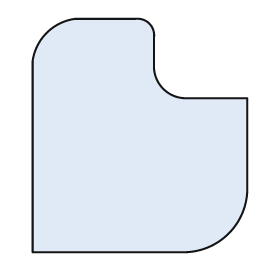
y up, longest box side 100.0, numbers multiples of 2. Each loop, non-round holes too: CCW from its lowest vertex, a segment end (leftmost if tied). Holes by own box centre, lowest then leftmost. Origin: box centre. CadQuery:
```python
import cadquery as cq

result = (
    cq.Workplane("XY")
    .moveTo(-46.0, -50.0)
    .lineTo(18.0, -50.0)
    .threePointArc((38.0, -42.0), (46.0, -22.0))
    .lineTo(46.0, 16.0)
    .lineTo(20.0, 16.0)
    .threePointArc((10.0, 20.0), (6.0, 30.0))
    .lineTo(6.0, 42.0)
    .threePointArc((4.0, 48.0), (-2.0, 50.0))
    .lineTo(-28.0, 50.0)
    .threePointArc((-40.0, 44.0), (-46.0, 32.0))
    .close()
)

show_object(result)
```